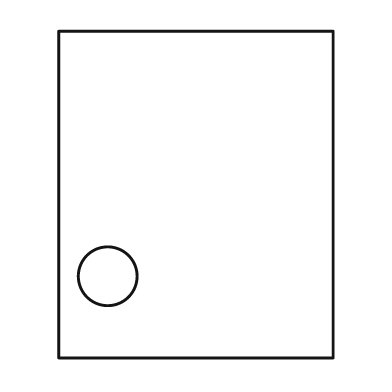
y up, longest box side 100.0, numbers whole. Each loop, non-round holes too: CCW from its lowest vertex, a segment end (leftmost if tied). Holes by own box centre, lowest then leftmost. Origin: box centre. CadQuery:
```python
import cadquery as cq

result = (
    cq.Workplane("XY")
    .moveTo(-42.0, -50.0)
    .lineTo(42.0, -50.0)
    .lineTo(42.0, 50.0)
    .lineTo(-42.0, 50.0)
    .close()
    .moveTo(-27.0, -25.0)
    .circle(9.0)
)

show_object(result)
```